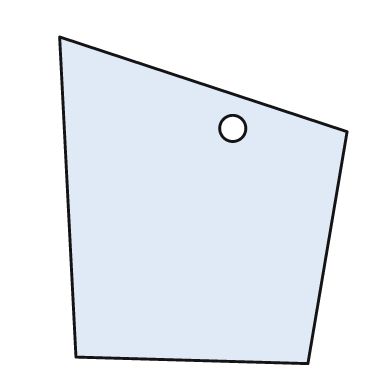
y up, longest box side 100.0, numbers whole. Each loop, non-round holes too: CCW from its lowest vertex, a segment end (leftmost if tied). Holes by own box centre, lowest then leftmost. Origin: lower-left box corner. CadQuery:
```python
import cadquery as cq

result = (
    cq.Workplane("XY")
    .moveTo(76.0, 0.0)
    .lineTo(88.0, 71.0)
    .lineTo(0.0, 100.0)
    .lineTo(5.0, 2.0)
    .close()
    .moveTo(53.0, 72.0)
    .circle(4.0)
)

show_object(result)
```